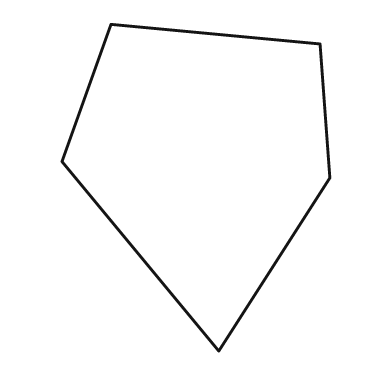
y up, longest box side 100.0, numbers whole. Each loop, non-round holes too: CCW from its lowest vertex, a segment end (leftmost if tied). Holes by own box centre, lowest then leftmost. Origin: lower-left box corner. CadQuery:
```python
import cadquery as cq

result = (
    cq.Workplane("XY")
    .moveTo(48.0, 0.0)
    .lineTo(82.0, 53.0)
    .lineTo(79.0, 94.0)
    .lineTo(15.0, 100.0)
    .lineTo(0.0, 58.0)
    .close()
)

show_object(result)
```